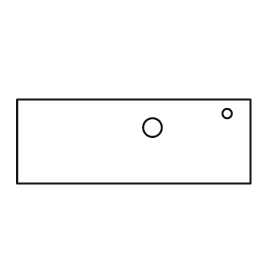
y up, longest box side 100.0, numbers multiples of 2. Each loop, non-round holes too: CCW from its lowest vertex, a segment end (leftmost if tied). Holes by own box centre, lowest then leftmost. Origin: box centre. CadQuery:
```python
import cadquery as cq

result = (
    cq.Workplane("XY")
    .moveTo(-50.0, -18.0)
    .lineTo(50.0, -18.0)
    .lineTo(50.0, 18.0)
    .lineTo(-50.0, 18.0)
    .close()
    .moveTo(8.0, 6.0)
    .circle(4.0)
    .moveTo(40.0, 12.0)
    .circle(2.0)
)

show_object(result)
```